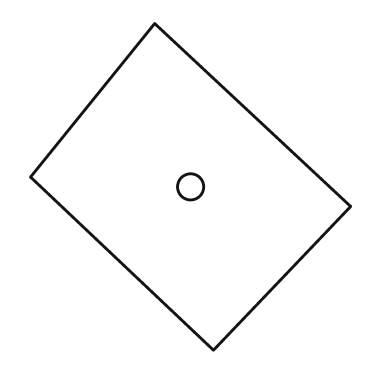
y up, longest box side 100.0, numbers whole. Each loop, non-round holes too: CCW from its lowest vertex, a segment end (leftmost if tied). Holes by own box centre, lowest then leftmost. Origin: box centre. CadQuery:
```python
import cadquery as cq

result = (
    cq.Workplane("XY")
    .moveTo(7.0, -50.0)
    .lineTo(49.0, -6.0)
    .lineTo(-11.0, 50.0)
    .lineTo(-49.0, 3.0)
    .close()
    .moveTo(0.0, 0.0)
    .circle(4.0)
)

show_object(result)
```